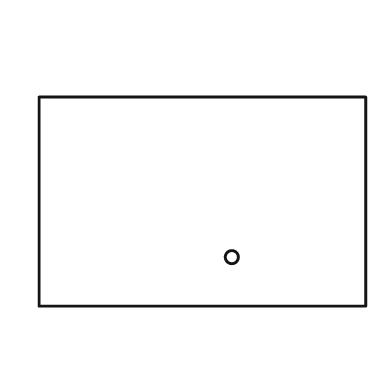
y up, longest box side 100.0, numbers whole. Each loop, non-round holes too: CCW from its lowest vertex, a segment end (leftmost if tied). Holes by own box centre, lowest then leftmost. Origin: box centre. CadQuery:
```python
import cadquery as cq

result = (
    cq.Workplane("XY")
    .moveTo(-50.0, -32.0)
    .lineTo(50.0, -32.0)
    .lineTo(50.0, 32.0)
    .lineTo(-50.0, 32.0)
    .close()
    .moveTo(9.0, -17.0)
    .circle(2.0)
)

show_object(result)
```